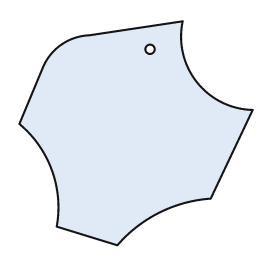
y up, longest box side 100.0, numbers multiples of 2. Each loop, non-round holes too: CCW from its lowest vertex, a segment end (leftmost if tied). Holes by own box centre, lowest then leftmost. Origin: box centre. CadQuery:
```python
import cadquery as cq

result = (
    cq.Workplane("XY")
    .moveTo(-8.0, -48.0)
    .threePointArc((10.0, -34.0), (32.0, -28.0))
    .lineTo(50.0, 10.0)
    .threePointArc((26.0, 22.0), (20.0, 48.0))
    .lineTo(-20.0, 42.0)
    .threePointArc((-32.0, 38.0), (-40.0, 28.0))
    .lineTo(-50.0, 4.0)
    .threePointArc((-36.0, -16.0), (-34.0, -40.0))
    .close()
    .moveTo(6.0, 36.0)
    .circle(2.0)
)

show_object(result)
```